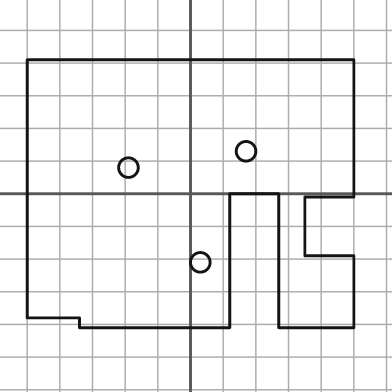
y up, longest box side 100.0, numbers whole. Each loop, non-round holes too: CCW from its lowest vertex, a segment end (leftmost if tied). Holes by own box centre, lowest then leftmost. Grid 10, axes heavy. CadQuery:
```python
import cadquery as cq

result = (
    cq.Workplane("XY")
    .moveTo(-34.0, -41.0)
    .lineTo(12.0, -41.0)
    .lineTo(12.0, 0.0)
    .lineTo(27.0, 0.0)
    .lineTo(27.0, -41.0)
    .lineTo(50.0, -41.0)
    .lineTo(50.0, -19.0)
    .lineTo(35.0, -19.0)
    .lineTo(35.0, -1.0)
    .lineTo(50.0, -1.0)
    .lineTo(50.0, 41.0)
    .lineTo(-50.0, 41.0)
    .lineTo(-50.0, -38.0)
    .lineTo(-34.0, -38.0)
    .close()
    .moveTo(3.0, -21.0)
    .circle(3.0)
    .moveTo(-19.0, 8.0)
    .circle(3.0)
    .moveTo(17.0, 13.0)
    .circle(3.0)
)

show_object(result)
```